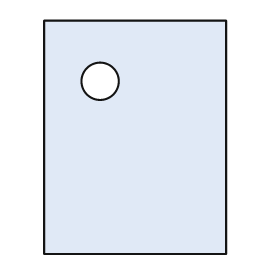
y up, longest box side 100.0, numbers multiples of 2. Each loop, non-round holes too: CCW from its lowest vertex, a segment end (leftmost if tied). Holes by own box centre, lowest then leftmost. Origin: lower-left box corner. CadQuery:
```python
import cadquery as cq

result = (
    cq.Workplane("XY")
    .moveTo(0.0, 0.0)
    .lineTo(78.0, 0.0)
    .lineTo(78.0, 100.0)
    .lineTo(0.0, 100.0)
    .close()
    .moveTo(24.0, 74.0)
    .circle(8.0)
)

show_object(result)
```